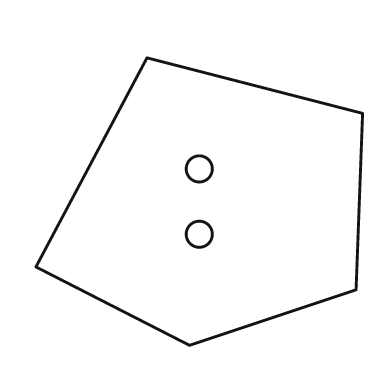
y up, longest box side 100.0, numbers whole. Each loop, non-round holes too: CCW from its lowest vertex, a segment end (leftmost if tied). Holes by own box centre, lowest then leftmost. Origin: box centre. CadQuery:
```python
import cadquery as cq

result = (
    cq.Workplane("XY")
    .moveTo(-3.0, -44.0)
    .lineTo(48.0, -27.0)
    .lineTo(50.0, 27.0)
    .lineTo(-16.0, 44.0)
    .lineTo(-50.0, -20.0)
    .close()
    .moveTo(0.0, -10.0)
    .circle(4.0)
    .moveTo(0.0, 10.0)
    .circle(4.0)
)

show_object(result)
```